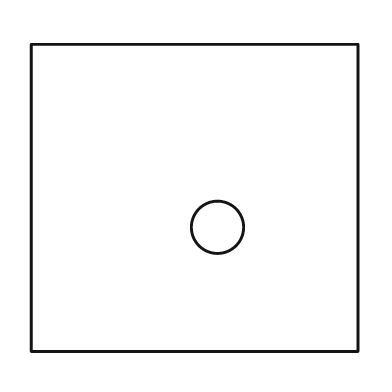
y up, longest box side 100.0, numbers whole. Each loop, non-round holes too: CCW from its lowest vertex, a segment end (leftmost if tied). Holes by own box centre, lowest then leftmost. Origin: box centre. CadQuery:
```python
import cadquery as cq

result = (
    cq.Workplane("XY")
    .moveTo(-50.0, -47.0)
    .lineTo(50.0, -47.0)
    .lineTo(50.0, 47.0)
    .lineTo(-50.0, 47.0)
    .close()
    .moveTo(7.0, -9.0)
    .circle(8.0)
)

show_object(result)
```